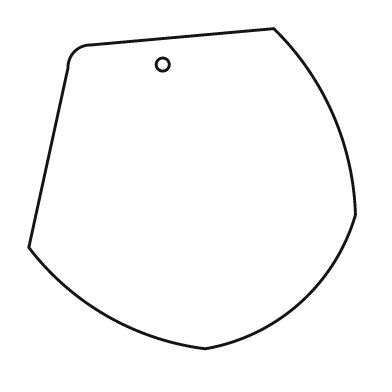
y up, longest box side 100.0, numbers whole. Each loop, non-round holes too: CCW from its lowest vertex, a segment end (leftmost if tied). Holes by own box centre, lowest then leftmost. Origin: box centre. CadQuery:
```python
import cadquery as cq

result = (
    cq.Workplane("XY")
    .moveTo(4.0, -49.0)
    .threePointArc((33.0, -35.0), (50.0, -8.0))
    .threePointArc((43.0, 23.0), (25.0, 49.0))
    .lineTo(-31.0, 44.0)
    .threePointArc((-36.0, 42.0), (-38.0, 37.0))
    .lineTo(-50.0, -18.0)
    .threePointArc((-26.0, -39.0), (4.0, -49.0))
    .close()
    .moveTo(-9.0, 38.0)
    .circle(2.0)
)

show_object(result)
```